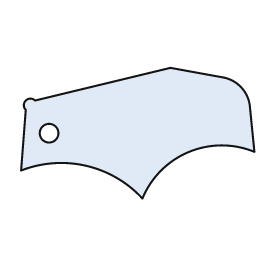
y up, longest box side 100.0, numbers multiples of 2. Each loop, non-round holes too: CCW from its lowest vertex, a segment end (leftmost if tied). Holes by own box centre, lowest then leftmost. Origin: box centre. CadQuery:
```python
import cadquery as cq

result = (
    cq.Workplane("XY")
    .moveTo(2.0, -28.0)
    .threePointArc((22.0, -8.0), (50.0, -8.0))
    .lineTo(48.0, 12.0)
    .threePointArc((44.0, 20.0), (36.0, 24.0))
    .lineTo(14.0, 28.0)
    .lineTo(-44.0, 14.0)
    .threePointArc((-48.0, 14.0), (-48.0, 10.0))
    .lineTo(-50.0, -16.0)
    .threePointArc((-22.0, -14.0), (2.0, -28.0))
    .close()
    .moveTo(-38.0, 0.0)
    .circle(4.0)
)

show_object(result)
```